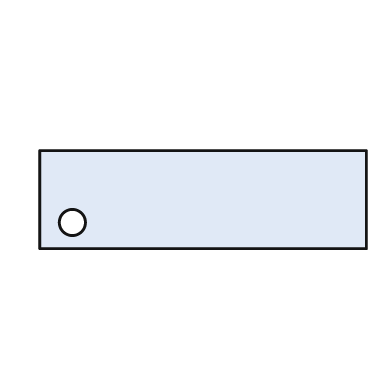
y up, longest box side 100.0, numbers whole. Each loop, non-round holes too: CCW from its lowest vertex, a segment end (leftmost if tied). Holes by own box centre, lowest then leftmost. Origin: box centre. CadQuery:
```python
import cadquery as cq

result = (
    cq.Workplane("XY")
    .moveTo(-50.0, -15.0)
    .lineTo(50.0, -15.0)
    .lineTo(50.0, 15.0)
    .lineTo(-50.0, 15.0)
    .close()
    .moveTo(-40.0, -7.0)
    .circle(4.0)
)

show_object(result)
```